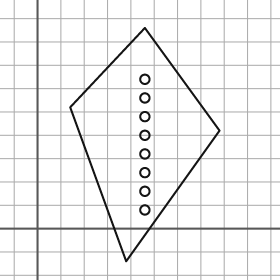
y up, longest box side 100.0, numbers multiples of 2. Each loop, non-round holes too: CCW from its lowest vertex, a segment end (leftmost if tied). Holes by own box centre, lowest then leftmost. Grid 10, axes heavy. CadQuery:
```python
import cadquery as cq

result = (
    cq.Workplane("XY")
    .moveTo(38.0, -14.0)
    .lineTo(78.0, 42.0)
    .lineTo(46.0, 86.0)
    .lineTo(14.0, 52.0)
    .close()
    .moveTo(46.0, 8.0)
    .circle(2.0)
    .moveTo(46.0, 16.0)
    .circle(2.0)
    .moveTo(46.0, 24.0)
    .circle(2.0)
    .moveTo(46.0, 32.0)
    .circle(2.0)
    .moveTo(46.0, 40.0)
    .circle(2.0)
    .moveTo(46.0, 48.0)
    .circle(2.0)
    .moveTo(46.0, 56.0)
    .circle(2.0)
    .moveTo(46.0, 64.0)
    .circle(2.0)
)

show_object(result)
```